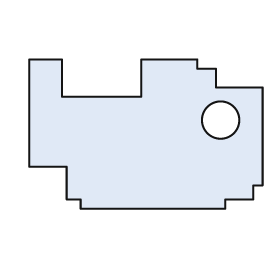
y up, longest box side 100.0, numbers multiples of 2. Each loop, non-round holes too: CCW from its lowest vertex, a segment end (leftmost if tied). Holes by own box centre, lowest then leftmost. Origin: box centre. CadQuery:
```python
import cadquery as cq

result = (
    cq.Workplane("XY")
    .moveTo(-28.0, -32.0)
    .lineTo(34.0, -32.0)
    .lineTo(34.0, -28.0)
    .lineTo(46.0, -28.0)
    .lineTo(46.0, -22.0)
    .lineTo(50.0, -22.0)
    .lineTo(50.0, 20.0)
    .lineTo(30.0, 20.0)
    .lineTo(30.0, 28.0)
    .lineTo(22.0, 28.0)
    .lineTo(22.0, 32.0)
    .lineTo(-2.0, 32.0)
    .lineTo(-2.0, 16.0)
    .lineTo(-36.0, 16.0)
    .lineTo(-36.0, 32.0)
    .lineTo(-50.0, 32.0)
    .lineTo(-50.0, -14.0)
    .lineTo(-34.0, -14.0)
    .lineTo(-34.0, -28.0)
    .lineTo(-28.0, -28.0)
    .close()
    .moveTo(32.0, 6.0)
    .circle(8.0)
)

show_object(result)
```